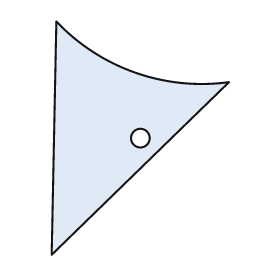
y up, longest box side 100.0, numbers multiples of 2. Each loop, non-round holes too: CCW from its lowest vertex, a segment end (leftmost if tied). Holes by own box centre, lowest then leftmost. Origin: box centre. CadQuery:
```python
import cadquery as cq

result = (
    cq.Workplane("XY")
    .moveTo(-38.0, -50.0)
    .lineTo(38.0, 24.0)
    .threePointArc((-2.0, 28.0), (-36.0, 50.0))
    .close()
    .moveTo(0.0, 0.0)
    .circle(4.0)
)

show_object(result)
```